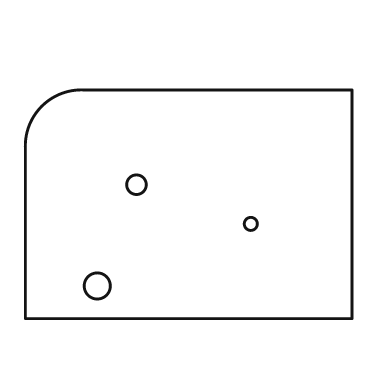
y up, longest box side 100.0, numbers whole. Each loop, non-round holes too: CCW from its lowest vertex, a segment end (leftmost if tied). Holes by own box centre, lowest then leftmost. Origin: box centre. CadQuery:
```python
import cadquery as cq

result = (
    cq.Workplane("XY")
    .moveTo(-50.0, -35.0)
    .lineTo(50.0, -35.0)
    .lineTo(50.0, 35.0)
    .lineTo(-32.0, 35.0)
    .threePointArc((-45.0, 30.0), (-50.0, 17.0))
    .close()
    .moveTo(-28.0, -25.0)
    .circle(4.0)
    .moveTo(19.0, -6.0)
    .circle(2.0)
    .moveTo(-16.0, 6.0)
    .circle(3.0)
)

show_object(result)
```